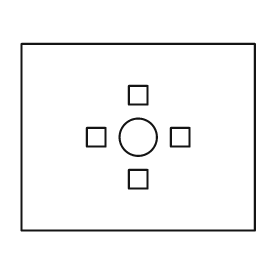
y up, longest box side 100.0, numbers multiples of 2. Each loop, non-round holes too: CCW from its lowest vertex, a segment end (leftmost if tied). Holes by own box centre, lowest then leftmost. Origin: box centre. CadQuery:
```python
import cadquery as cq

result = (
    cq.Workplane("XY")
    .moveTo(-50.0, -40.0)
    .lineTo(50.0, -40.0)
    .lineTo(50.0, 40.0)
    .lineTo(-50.0, 40.0)
    .close()
    .moveTo(-4.0, -22.0)
    .lineTo(4.0, -22.0)
    .lineTo(4.0, -14.0)
    .lineTo(-4.0, -14.0)
    .close()
    .moveTo(-22.0, -4.0)
    .lineTo(-14.0, -4.0)
    .lineTo(-14.0, 4.0)
    .lineTo(-22.0, 4.0)
    .close()
    .moveTo(0.0, 0.0)
    .circle(8.0)
    .moveTo(14.0, -4.0)
    .lineTo(22.0, -4.0)
    .lineTo(22.0, 4.0)
    .lineTo(14.0, 4.0)
    .close()
    .moveTo(-4.0, 14.0)
    .lineTo(4.0, 14.0)
    .lineTo(4.0, 22.0)
    .lineTo(-4.0, 22.0)
    .close()
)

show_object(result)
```